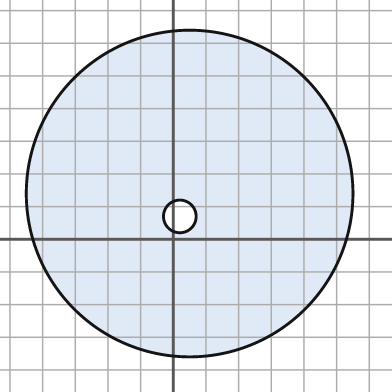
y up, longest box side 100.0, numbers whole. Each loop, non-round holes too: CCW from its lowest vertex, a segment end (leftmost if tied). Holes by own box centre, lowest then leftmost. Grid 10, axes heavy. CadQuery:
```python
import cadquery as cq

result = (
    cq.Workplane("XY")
    .moveTo(5.0, 14.0)
    .circle(50.0)
    .moveTo(2.0, 7.0)
    .circle(5.0)
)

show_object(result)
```